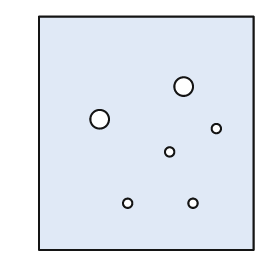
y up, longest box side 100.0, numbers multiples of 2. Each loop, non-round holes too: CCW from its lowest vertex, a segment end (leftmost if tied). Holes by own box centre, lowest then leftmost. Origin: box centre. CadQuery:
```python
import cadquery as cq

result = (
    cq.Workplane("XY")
    .moveTo(-46.0, -50.0)
    .lineTo(46.0, -50.0)
    .lineTo(46.0, 50.0)
    .lineTo(-46.0, 50.0)
    .close()
    .moveTo(-8.0, -30.0)
    .circle(2.0)
    .moveTo(20.0, -30.0)
    .circle(2.0)
    .moveTo(10.0, -8.0)
    .circle(2.0)
    .moveTo(30.0, 2.0)
    .circle(2.0)
    .moveTo(-20.0, 6.0)
    .circle(4.0)
    .moveTo(16.0, 20.0)
    .circle(4.0)
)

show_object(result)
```